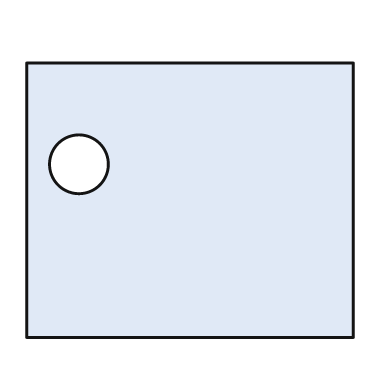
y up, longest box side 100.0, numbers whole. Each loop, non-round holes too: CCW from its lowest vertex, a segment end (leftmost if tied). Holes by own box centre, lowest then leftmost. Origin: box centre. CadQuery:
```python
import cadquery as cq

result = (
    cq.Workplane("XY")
    .moveTo(-50.0, -42.0)
    .lineTo(50.0, -42.0)
    .lineTo(50.0, 42.0)
    .lineTo(-50.0, 42.0)
    .close()
    .moveTo(-34.0, 11.0)
    .circle(9.0)
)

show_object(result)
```